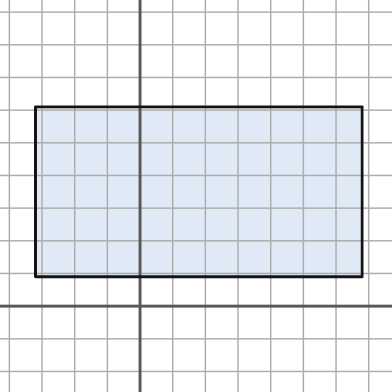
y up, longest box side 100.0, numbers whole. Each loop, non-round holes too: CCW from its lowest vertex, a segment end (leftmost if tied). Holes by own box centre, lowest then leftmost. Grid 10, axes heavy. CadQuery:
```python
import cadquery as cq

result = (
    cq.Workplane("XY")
    .moveTo(-32.0, 9.0)
    .lineTo(68.0, 9.0)
    .lineTo(68.0, 61.0)
    .lineTo(-32.0, 61.0)
    .close()
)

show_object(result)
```